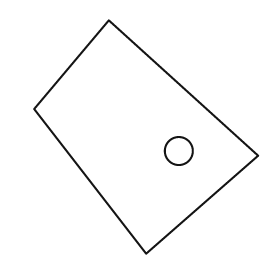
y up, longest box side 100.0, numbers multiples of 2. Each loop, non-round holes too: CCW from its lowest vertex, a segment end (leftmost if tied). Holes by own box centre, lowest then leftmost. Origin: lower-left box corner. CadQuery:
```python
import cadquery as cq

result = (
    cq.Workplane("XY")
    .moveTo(48.0, 0.0)
    .lineTo(96.0, 42.0)
    .lineTo(32.0, 100.0)
    .lineTo(0.0, 62.0)
    .close()
    .moveTo(62.0, 44.0)
    .circle(6.0)
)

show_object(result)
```